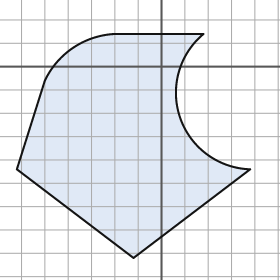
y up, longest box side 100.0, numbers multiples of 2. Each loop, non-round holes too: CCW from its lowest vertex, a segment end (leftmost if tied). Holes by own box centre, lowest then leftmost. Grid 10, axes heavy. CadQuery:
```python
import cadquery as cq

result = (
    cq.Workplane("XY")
    .moveTo(-12.0, -82.0)
    .lineTo(38.0, -44.0)
    .threePointArc((8.0, -22.0), (18.0, 14.0))
    .lineTo(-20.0, 14.0)
    .threePointArc((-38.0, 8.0), (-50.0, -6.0))
    .lineTo(-62.0, -44.0)
    .close()
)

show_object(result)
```